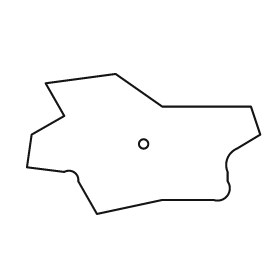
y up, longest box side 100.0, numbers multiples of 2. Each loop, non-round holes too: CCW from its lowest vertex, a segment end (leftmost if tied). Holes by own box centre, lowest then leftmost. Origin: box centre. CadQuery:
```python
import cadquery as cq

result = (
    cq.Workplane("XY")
    .moveTo(-20.0, -30.0)
    .lineTo(8.0, -24.0)
    .lineTo(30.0, -24.0)
    .threePointArc((36.0, -22.0), (36.0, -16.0))
    .lineTo(36.0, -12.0)
    .threePointArc((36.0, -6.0), (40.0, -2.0))
    .lineTo(50.0, 4.0)
    .lineTo(46.0, 16.0)
    .lineTo(8.0, 16.0)
    .lineTo(-12.0, 30.0)
    .lineTo(-42.0, 26.0)
    .lineTo(-34.0, 12.0)
    .lineTo(-48.0, 4.0)
    .lineTo(-50.0, -10.0)
    .lineTo(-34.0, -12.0)
    .threePointArc((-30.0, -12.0), (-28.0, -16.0))
    .close()
    .moveTo(0.0, 0.0)
    .circle(2.0)
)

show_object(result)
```